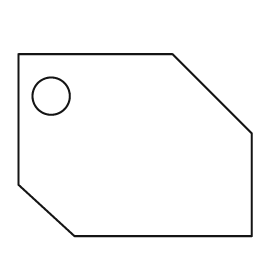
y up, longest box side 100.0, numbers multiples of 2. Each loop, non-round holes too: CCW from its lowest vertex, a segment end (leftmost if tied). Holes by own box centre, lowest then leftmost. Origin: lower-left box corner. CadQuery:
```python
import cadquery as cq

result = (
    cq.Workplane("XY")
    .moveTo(24.0, 0.0)
    .lineTo(100.0, 0.0)
    .lineTo(100.0, 44.0)
    .lineTo(66.0, 78.0)
    .lineTo(0.0, 78.0)
    .lineTo(0.0, 22.0)
    .close()
    .moveTo(14.0, 60.0)
    .circle(8.0)
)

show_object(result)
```